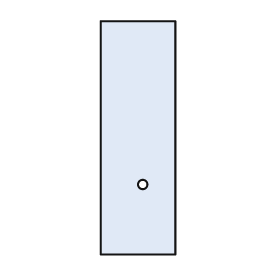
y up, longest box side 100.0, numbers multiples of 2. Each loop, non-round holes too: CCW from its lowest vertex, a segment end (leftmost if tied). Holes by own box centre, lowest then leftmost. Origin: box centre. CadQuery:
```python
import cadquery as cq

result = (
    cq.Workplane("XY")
    .moveTo(-16.0, -50.0)
    .lineTo(16.0, -50.0)
    .lineTo(16.0, 50.0)
    .lineTo(-16.0, 50.0)
    .close()
    .moveTo(2.0, -20.0)
    .circle(2.0)
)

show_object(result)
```